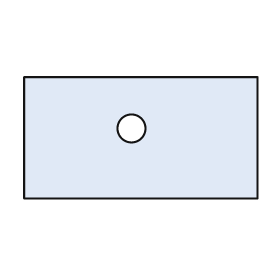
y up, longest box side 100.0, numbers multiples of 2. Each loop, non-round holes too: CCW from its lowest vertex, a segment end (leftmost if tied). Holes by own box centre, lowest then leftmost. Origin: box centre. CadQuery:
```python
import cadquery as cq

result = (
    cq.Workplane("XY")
    .moveTo(-50.0, -26.0)
    .lineTo(50.0, -26.0)
    .lineTo(50.0, 26.0)
    .lineTo(-50.0, 26.0)
    .close()
    .moveTo(-4.0, 4.0)
    .circle(6.0)
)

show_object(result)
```